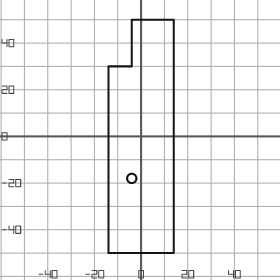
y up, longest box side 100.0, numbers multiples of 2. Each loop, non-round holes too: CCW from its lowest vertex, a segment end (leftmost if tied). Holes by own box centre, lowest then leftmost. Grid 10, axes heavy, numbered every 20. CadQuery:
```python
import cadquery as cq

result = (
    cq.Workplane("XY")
    .moveTo(-14.0, -50.0)
    .lineTo(14.0, -50.0)
    .lineTo(14.0, 50.0)
    .lineTo(-4.0, 50.0)
    .lineTo(-4.0, 30.0)
    .lineTo(-14.0, 30.0)
    .close()
    .moveTo(-4.0, -18.0)
    .circle(2.0)
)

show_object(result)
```